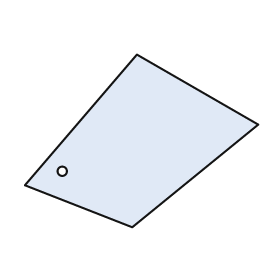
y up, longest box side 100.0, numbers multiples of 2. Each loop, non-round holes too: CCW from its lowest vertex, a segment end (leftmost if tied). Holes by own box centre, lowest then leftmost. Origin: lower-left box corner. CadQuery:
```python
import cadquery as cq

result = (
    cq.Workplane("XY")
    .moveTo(46.0, 0.0)
    .lineTo(100.0, 44.0)
    .lineTo(48.0, 74.0)
    .lineTo(0.0, 18.0)
    .close()
    .moveTo(16.0, 24.0)
    .circle(2.0)
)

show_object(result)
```